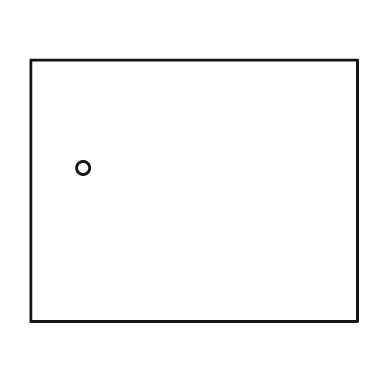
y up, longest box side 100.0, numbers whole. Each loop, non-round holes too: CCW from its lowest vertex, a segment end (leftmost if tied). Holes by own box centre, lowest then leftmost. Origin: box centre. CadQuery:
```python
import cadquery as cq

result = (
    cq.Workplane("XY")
    .moveTo(-50.0, -40.0)
    .lineTo(50.0, -40.0)
    .lineTo(50.0, 40.0)
    .lineTo(-50.0, 40.0)
    .close()
    .moveTo(-34.0, 7.0)
    .circle(2.0)
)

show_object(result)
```